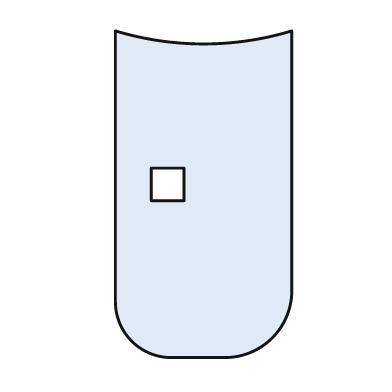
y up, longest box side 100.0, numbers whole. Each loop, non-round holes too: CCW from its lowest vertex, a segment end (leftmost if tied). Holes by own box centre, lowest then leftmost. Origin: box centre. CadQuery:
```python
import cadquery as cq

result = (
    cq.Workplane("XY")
    .moveTo(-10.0, -50.0)
    .lineTo(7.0, -50.0)
    .threePointArc((21.0, -44.0), (27.0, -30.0))
    .lineTo(27.0, 50.0)
    .threePointArc((0.0, 46.0), (-27.0, 50.0))
    .lineTo(-27.0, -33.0)
    .threePointArc((-22.0, -45.0), (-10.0, -50.0))
    .close()
    .moveTo(-16.0, -2.0)
    .lineTo(-6.0, -2.0)
    .lineTo(-6.0, 8.0)
    .lineTo(-16.0, 8.0)
    .close()
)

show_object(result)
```